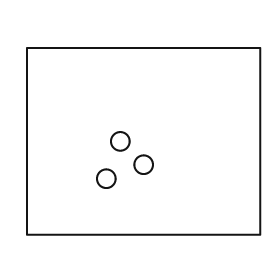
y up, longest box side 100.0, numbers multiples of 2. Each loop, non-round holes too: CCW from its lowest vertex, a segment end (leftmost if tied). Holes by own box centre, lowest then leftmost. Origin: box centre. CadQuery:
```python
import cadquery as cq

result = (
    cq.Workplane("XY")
    .moveTo(-50.0, -40.0)
    .lineTo(50.0, -40.0)
    .lineTo(50.0, 40.0)
    .lineTo(-50.0, 40.0)
    .close()
    .moveTo(-16.0, -16.0)
    .circle(4.0)
    .moveTo(0.0, -10.0)
    .circle(4.0)
    .moveTo(-10.0, 0.0)
    .circle(4.0)
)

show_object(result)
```